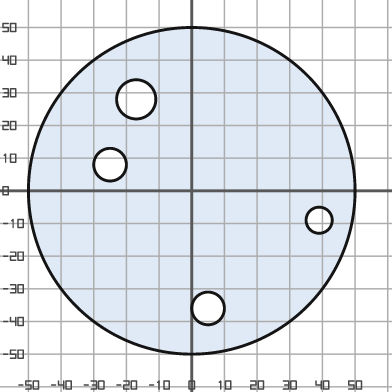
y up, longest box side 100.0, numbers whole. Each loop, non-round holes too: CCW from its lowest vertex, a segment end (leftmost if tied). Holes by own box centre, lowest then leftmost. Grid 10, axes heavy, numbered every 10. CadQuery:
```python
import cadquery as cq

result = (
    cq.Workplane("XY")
    .moveTo(0.0, 0.0)
    .circle(50.0)
    .moveTo(5.0, -36.0)
    .circle(5.0)
    .moveTo(39.0, -9.0)
    .circle(4.0)
    .moveTo(-25.0, 8.0)
    .circle(5.0)
    .moveTo(-17.0, 28.0)
    .circle(6.0)
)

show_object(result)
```